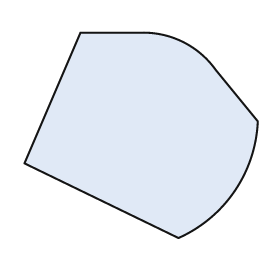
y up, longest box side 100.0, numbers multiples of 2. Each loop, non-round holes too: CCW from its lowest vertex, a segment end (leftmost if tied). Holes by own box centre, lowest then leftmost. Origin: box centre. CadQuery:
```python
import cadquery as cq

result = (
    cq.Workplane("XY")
    .moveTo(16.0, -44.0)
    .threePointArc((40.0, -24.0), (50.0, 6.0))
    .lineTo(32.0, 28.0)
    .threePointArc((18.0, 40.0), (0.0, 44.0))
    .lineTo(-26.0, 44.0)
    .lineTo(-50.0, -12.0)
    .close()
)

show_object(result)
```